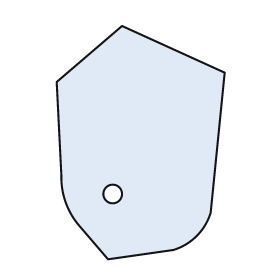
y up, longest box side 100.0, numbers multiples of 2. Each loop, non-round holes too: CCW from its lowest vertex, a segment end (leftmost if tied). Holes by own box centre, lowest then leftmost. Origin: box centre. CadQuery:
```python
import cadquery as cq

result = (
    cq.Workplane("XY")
    .moveTo(-14.0, -50.0)
    .lineTo(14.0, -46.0)
    .threePointArc((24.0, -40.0), (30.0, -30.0))
    .lineTo(36.0, 30.0)
    .lineTo(-8.0, 50.0)
    .lineTo(-36.0, 26.0)
    .lineTo(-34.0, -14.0)
    .threePointArc((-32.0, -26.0), (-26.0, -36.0))
    .close()
    .moveTo(-12.0, -22.0)
    .circle(4.0)
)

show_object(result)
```